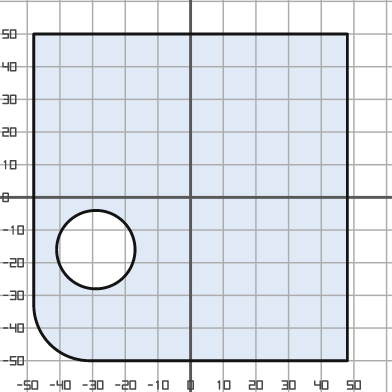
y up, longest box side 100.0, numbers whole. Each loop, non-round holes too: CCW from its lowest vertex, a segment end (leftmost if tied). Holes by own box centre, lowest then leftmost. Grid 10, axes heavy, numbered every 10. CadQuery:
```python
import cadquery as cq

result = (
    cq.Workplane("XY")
    .moveTo(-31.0, -50.0)
    .lineTo(48.0, -50.0)
    .lineTo(48.0, 50.0)
    .lineTo(-48.0, 50.0)
    .lineTo(-48.0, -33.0)
    .threePointArc((-43.0, -45.0), (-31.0, -50.0))
    .close()
    .moveTo(-29.0, -16.0)
    .circle(12.0)
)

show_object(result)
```